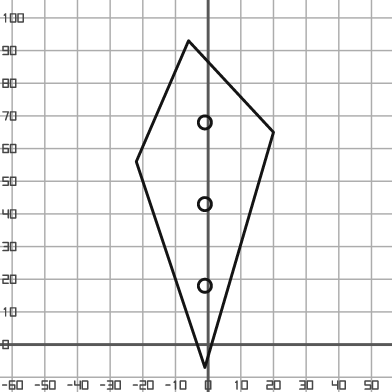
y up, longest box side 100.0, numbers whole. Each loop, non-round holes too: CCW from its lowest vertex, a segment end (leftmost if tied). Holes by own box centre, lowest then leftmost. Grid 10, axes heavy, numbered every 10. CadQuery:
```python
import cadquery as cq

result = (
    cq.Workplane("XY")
    .moveTo(-1.0, -7.0)
    .lineTo(20.0, 65.0)
    .lineTo(-6.0, 93.0)
    .lineTo(-22.0, 56.0)
    .close()
    .moveTo(-1.0, 18.0)
    .circle(2.0)
    .moveTo(-1.0, 43.0)
    .circle(2.0)
    .moveTo(-1.0, 68.0)
    .circle(2.0)
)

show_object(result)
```